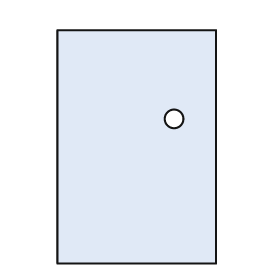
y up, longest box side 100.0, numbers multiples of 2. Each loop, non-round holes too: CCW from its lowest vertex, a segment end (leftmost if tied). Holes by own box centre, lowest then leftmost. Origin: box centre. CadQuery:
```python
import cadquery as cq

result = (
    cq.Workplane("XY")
    .moveTo(-34.0, -50.0)
    .lineTo(34.0, -50.0)
    .lineTo(34.0, 50.0)
    .lineTo(-34.0, 50.0)
    .close()
    .moveTo(16.0, 12.0)
    .circle(4.0)
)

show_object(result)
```